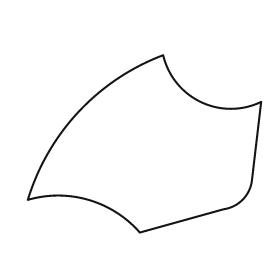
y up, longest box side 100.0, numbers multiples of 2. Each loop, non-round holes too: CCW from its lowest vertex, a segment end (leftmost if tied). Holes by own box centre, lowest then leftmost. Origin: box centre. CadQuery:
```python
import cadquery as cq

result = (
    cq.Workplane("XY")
    .moveTo(-2.0, -38.0)
    .lineTo(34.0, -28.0)
    .threePointArc((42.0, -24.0), (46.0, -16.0))
    .lineTo(50.0, 18.0)
    .threePointArc((24.0, 18.0), (8.0, 38.0))
    .threePointArc((-28.0, 14.0), (-50.0, -24.0))
    .threePointArc((-24.0, -24.0), (-2.0, -38.0))
    .close()
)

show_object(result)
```